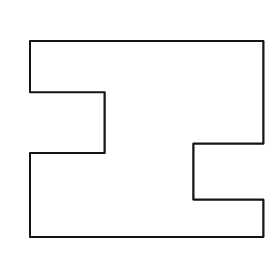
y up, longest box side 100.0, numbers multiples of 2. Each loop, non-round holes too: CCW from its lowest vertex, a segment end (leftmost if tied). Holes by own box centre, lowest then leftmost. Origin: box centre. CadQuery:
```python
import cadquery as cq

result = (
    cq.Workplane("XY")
    .moveTo(-50.0, -42.0)
    .lineTo(50.0, -42.0)
    .lineTo(50.0, -26.0)
    .lineTo(20.0, -26.0)
    .lineTo(20.0, -2.0)
    .lineTo(50.0, -2.0)
    .lineTo(50.0, 42.0)
    .lineTo(-50.0, 42.0)
    .lineTo(-50.0, 20.0)
    .lineTo(-18.0, 20.0)
    .lineTo(-18.0, -6.0)
    .lineTo(-50.0, -6.0)
    .close()
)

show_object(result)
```